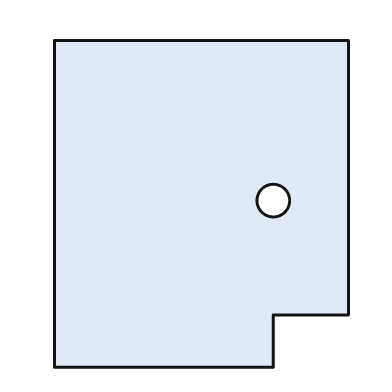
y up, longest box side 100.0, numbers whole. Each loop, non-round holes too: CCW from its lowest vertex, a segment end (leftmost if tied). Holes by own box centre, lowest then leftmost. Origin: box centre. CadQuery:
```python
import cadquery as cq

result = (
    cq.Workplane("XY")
    .moveTo(-45.0, -50.0)
    .lineTo(22.0, -50.0)
    .lineTo(22.0, -34.0)
    .lineTo(45.0, -34.0)
    .lineTo(45.0, 50.0)
    .lineTo(-45.0, 50.0)
    .close()
    .moveTo(22.0, 1.0)
    .circle(5.0)
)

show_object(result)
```